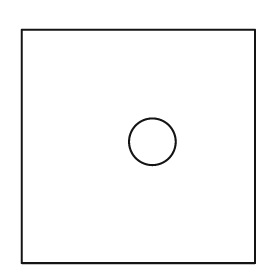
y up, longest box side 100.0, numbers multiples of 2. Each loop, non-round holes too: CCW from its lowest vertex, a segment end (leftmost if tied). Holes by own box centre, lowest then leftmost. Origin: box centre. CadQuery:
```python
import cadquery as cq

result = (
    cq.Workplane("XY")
    .moveTo(-50.0, -50.0)
    .lineTo(50.0, -50.0)
    .lineTo(50.0, 50.0)
    .lineTo(-50.0, 50.0)
    .close()
    .moveTo(6.0, 2.0)
    .circle(10.0)
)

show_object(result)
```